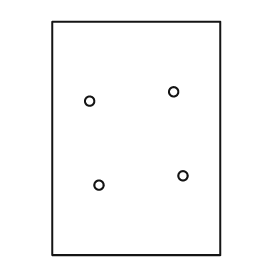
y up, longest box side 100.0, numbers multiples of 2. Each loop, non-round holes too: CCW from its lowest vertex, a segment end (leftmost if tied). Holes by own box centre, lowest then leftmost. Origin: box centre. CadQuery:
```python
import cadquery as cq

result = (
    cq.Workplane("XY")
    .moveTo(-36.0, -50.0)
    .lineTo(36.0, -50.0)
    .lineTo(36.0, 50.0)
    .lineTo(-36.0, 50.0)
    .close()
    .moveTo(-16.0, -20.0)
    .circle(2.0)
    .moveTo(20.0, -16.0)
    .circle(2.0)
    .moveTo(-20.0, 16.0)
    .circle(2.0)
    .moveTo(16.0, 20.0)
    .circle(2.0)
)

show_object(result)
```